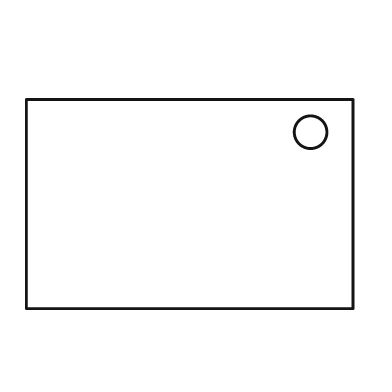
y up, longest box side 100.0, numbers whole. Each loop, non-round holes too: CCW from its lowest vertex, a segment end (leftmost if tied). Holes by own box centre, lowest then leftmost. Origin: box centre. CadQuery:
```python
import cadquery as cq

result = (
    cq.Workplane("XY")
    .moveTo(-50.0, -32.0)
    .lineTo(50.0, -32.0)
    .lineTo(50.0, 32.0)
    .lineTo(-50.0, 32.0)
    .close()
    .moveTo(37.0, 22.0)
    .circle(5.0)
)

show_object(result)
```